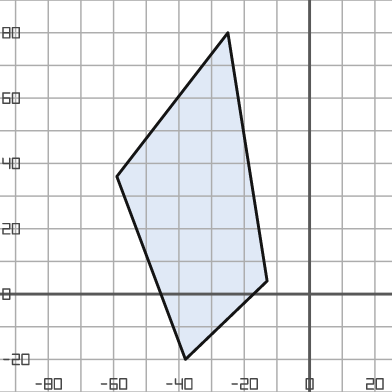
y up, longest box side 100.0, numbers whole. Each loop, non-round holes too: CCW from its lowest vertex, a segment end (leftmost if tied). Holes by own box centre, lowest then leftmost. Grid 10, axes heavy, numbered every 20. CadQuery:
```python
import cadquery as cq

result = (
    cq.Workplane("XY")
    .moveTo(-38.0, -20.0)
    .lineTo(-13.0, 4.0)
    .lineTo(-25.0, 80.0)
    .lineTo(-59.0, 36.0)
    .close()
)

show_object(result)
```